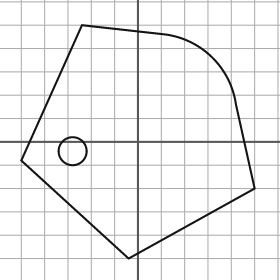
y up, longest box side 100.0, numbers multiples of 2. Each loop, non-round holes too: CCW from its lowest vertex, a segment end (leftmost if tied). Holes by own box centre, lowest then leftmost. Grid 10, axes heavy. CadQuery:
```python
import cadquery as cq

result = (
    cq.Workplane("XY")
    .moveTo(-4.0, -50.0)
    .lineTo(50.0, -20.0)
    .lineTo(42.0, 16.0)
    .threePointArc((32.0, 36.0), (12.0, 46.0))
    .lineTo(-24.0, 50.0)
    .lineTo(-50.0, -8.0)
    .close()
    .moveTo(-28.0, -4.0)
    .circle(6.0)
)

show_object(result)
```